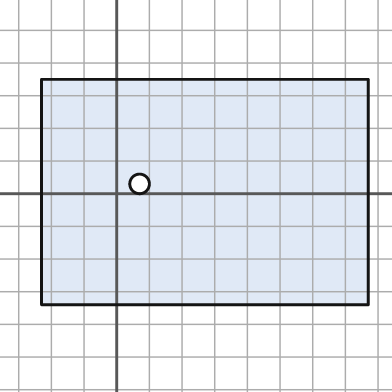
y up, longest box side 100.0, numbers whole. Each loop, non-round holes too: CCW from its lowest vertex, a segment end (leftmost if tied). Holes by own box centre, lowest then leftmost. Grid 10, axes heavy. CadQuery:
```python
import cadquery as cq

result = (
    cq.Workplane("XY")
    .moveTo(-23.0, -34.0)
    .lineTo(77.0, -34.0)
    .lineTo(77.0, 35.0)
    .lineTo(-23.0, 35.0)
    .close()
    .moveTo(7.0, 3.0)
    .circle(3.0)
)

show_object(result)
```